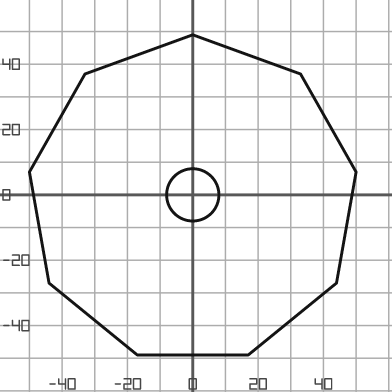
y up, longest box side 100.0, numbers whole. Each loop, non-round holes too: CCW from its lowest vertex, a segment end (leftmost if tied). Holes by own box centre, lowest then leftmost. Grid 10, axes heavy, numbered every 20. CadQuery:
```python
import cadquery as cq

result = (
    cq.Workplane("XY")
    .moveTo(-17.0, -49.0)
    .lineTo(17.0, -49.0)
    .lineTo(44.0, -27.0)
    .lineTo(50.0, 7.0)
    .lineTo(33.0, 37.0)
    .lineTo(0.0, 49.0)
    .lineTo(-33.0, 37.0)
    .lineTo(-50.0, 7.0)
    .lineTo(-44.0, -27.0)
    .close()
    .moveTo(0.0, 0.0)
    .circle(8.0)
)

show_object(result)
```